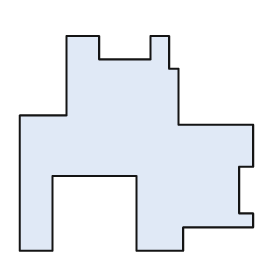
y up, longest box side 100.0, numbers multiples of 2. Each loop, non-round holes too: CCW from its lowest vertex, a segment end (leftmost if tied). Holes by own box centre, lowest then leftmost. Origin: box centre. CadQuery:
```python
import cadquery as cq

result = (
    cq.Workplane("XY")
    .moveTo(-50.0, -46.0)
    .lineTo(-36.0, -46.0)
    .lineTo(-36.0, -14.0)
    .lineTo(0.0, -14.0)
    .lineTo(0.0, -46.0)
    .lineTo(20.0, -46.0)
    .lineTo(20.0, -36.0)
    .lineTo(50.0, -36.0)
    .lineTo(50.0, -30.0)
    .lineTo(44.0, -30.0)
    .lineTo(44.0, -10.0)
    .lineTo(50.0, -10.0)
    .lineTo(50.0, 8.0)
    .lineTo(18.0, 8.0)
    .lineTo(18.0, 32.0)
    .lineTo(14.0, 32.0)
    .lineTo(14.0, 46.0)
    .lineTo(6.0, 46.0)
    .lineTo(6.0, 36.0)
    .lineTo(-16.0, 36.0)
    .lineTo(-16.0, 46.0)
    .lineTo(-30.0, 46.0)
    .lineTo(-30.0, 12.0)
    .lineTo(-50.0, 12.0)
    .close()
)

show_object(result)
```